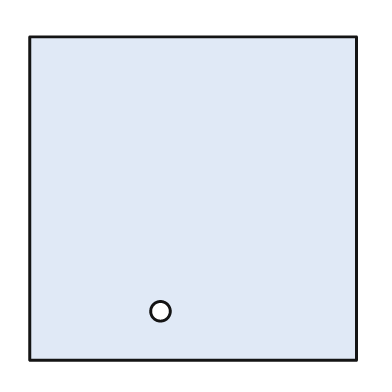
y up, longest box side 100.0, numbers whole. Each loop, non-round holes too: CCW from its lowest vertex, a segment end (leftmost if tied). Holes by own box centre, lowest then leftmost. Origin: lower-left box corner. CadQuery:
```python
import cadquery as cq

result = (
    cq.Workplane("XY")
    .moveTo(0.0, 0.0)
    .lineTo(100.0, 0.0)
    .lineTo(100.0, 99.0)
    .lineTo(0.0, 99.0)
    .close()
    .moveTo(40.0, 15.0)
    .circle(3.0)
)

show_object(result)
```